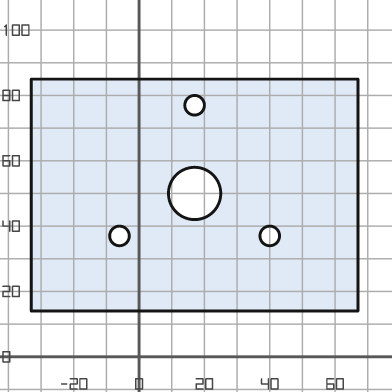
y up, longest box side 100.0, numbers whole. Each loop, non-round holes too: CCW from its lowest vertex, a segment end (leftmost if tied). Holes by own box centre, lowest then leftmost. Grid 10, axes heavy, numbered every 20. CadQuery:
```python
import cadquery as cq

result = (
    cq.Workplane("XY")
    .moveTo(-33.0, 14.0)
    .lineTo(67.0, 14.0)
    .lineTo(67.0, 85.0)
    .lineTo(-33.0, 85.0)
    .close()
    .moveTo(-6.0, 37.0)
    .circle(3.0)
    .moveTo(40.0, 37.0)
    .circle(3.0)
    .moveTo(17.0, 50.0)
    .circle(8.0)
    .moveTo(17.0, 77.0)
    .circle(3.0)
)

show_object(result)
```